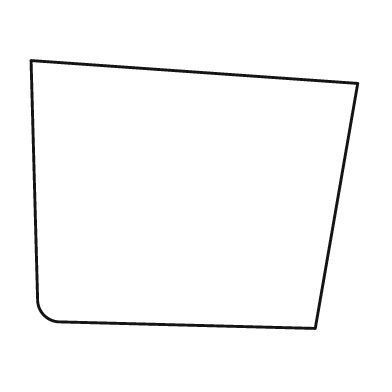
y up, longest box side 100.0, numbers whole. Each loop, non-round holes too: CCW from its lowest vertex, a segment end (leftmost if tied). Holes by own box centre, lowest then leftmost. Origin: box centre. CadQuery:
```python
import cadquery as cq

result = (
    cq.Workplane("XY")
    .moveTo(37.0, -41.0)
    .lineTo(50.0, 34.0)
    .lineTo(-50.0, 41.0)
    .lineTo(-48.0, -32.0)
    .threePointArc((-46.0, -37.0), (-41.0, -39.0))
    .close()
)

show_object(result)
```